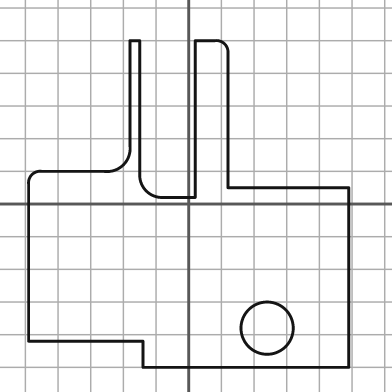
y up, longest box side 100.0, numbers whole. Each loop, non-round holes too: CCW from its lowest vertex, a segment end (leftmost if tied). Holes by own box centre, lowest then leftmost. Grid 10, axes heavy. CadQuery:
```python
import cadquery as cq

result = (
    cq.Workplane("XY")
    .moveTo(-14.0, -50.0)
    .lineTo(49.0, -50.0)
    .lineTo(49.0, 5.0)
    .lineTo(12.0, 5.0)
    .lineTo(12.0, 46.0)
    .threePointArc((11.0, 49.0), (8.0, 50.0))
    .lineTo(2.0, 50.0)
    .lineTo(2.0, 2.0)
    .lineTo(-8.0, 2.0)
    .threePointArc((-13.0, 4.0), (-15.0, 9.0))
    .lineTo(-15.0, 50.0)
    .lineTo(-18.0, 50.0)
    .lineTo(-18.0, 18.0)
    .threePointArc((-20.0, 12.0), (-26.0, 10.0))
    .lineTo(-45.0, 10.0)
    .threePointArc((-48.0, 9.0), (-49.0, 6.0))
    .lineTo(-49.0, -42.0)
    .lineTo(-14.0, -42.0)
    .close()
    .moveTo(24.0, -38.0)
    .circle(8.0)
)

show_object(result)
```